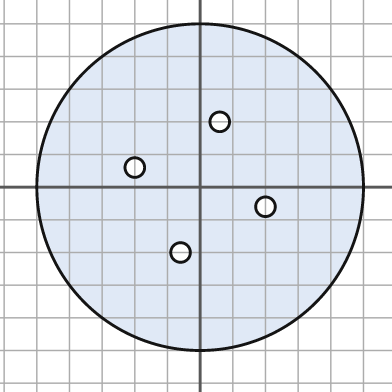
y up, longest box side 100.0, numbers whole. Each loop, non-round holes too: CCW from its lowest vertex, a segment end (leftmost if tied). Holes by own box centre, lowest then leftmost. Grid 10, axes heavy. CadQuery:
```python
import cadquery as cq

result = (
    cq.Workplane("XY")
    .moveTo(0.0, 0.0)
    .circle(50.0)
    .moveTo(-6.0, -20.0)
    .circle(3.0)
    .moveTo(20.0, -6.0)
    .circle(3.0)
    .moveTo(-20.0, 6.0)
    .circle(3.0)
    .moveTo(6.0, 20.0)
    .circle(3.0)
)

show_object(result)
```